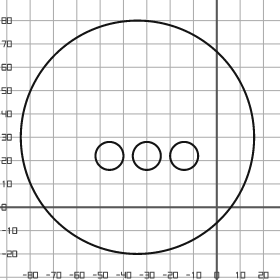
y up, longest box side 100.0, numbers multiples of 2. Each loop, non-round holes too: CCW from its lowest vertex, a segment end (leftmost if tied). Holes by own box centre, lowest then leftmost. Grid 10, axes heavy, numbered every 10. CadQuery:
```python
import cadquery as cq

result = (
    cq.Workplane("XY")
    .moveTo(-34.0, 30.0)
    .circle(50.0)
    .moveTo(-46.0, 22.0)
    .circle(6.0)
    .moveTo(-30.0, 22.0)
    .circle(6.0)
    .moveTo(-14.0, 22.0)
    .circle(6.0)
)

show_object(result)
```